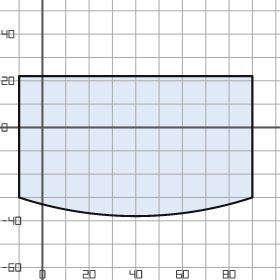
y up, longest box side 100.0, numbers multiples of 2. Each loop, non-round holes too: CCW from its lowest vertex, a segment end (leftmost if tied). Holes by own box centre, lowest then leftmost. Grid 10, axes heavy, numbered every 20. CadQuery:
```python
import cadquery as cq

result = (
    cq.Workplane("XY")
    .moveTo(-10.0, -30.0)
    .threePointArc((40.0, -38.0), (90.0, -30.0))
    .lineTo(90.0, 22.0)
    .lineTo(-10.0, 22.0)
    .close()
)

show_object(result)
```